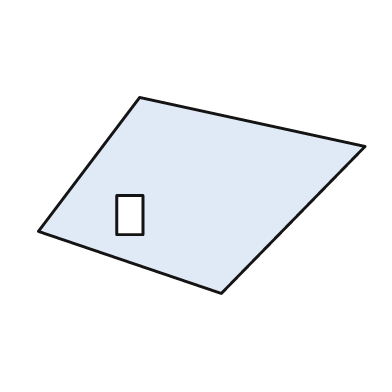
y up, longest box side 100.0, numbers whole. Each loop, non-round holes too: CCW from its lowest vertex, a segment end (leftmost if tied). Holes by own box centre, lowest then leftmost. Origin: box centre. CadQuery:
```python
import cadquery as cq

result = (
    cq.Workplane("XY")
    .moveTo(6.0, -30.0)
    .lineTo(50.0, 15.0)
    .lineTo(-19.0, 30.0)
    .lineTo(-50.0, -11.0)
    .close()
    .moveTo(-26.0, -12.0)
    .lineTo(-18.0, -12.0)
    .lineTo(-18.0, 0.0)
    .lineTo(-26.0, 0.0)
    .close()
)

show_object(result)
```